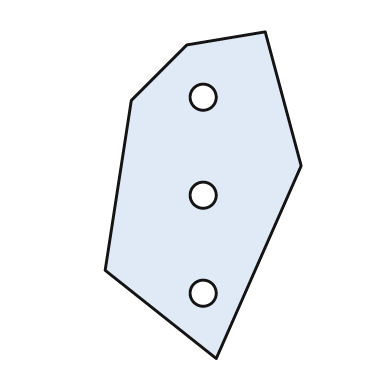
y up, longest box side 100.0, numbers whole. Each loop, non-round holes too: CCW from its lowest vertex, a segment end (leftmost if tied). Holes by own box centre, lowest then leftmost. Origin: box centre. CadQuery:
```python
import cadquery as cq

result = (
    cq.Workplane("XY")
    .moveTo(4.0, -50.0)
    .lineTo(30.0, 9.0)
    .lineTo(19.0, 50.0)
    .lineTo(-5.0, 46.0)
    .lineTo(-22.0, 29.0)
    .lineTo(-30.0, -23.0)
    .close()
    .moveTo(0.0, -30.0)
    .circle(4.0)
    .moveTo(0.0, 0.0)
    .circle(4.0)
    .moveTo(0.0, 30.0)
    .circle(4.0)
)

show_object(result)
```